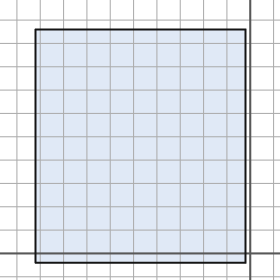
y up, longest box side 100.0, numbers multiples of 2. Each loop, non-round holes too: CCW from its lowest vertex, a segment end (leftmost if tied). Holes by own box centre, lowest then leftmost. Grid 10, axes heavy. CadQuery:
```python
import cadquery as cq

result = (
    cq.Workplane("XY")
    .moveTo(-92.0, -4.0)
    .lineTo(-2.0, -4.0)
    .lineTo(-2.0, 96.0)
    .lineTo(-92.0, 96.0)
    .close()
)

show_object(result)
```